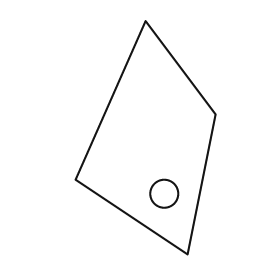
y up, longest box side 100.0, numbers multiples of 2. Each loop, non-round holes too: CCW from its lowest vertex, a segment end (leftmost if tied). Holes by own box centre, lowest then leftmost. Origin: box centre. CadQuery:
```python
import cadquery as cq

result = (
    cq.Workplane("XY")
    .moveTo(18.0, -50.0)
    .lineTo(30.0, 10.0)
    .lineTo(0.0, 50.0)
    .lineTo(-30.0, -18.0)
    .close()
    .moveTo(8.0, -24.0)
    .circle(6.0)
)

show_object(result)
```